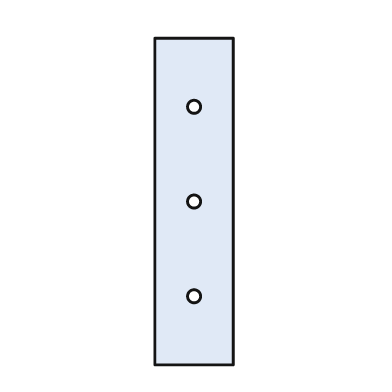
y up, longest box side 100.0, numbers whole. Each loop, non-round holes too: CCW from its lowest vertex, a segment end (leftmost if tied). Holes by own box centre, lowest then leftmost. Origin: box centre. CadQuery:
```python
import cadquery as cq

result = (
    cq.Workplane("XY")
    .moveTo(-12.0, -50.0)
    .lineTo(12.0, -50.0)
    .lineTo(12.0, 50.0)
    .lineTo(-12.0, 50.0)
    .close()
    .moveTo(0.0, -29.0)
    .circle(2.0)
    .moveTo(0.0, 0.0)
    .circle(2.0)
    .moveTo(0.0, 29.0)
    .circle(2.0)
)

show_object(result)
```